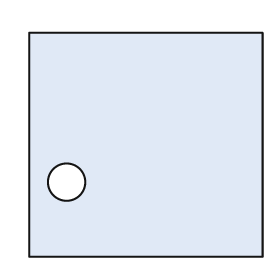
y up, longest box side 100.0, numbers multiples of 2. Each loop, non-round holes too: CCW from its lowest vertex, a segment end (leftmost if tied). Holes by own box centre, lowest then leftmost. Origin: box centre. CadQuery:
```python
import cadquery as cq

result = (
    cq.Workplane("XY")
    .moveTo(-50.0, -48.0)
    .lineTo(50.0, -48.0)
    .lineTo(50.0, 48.0)
    .lineTo(-50.0, 48.0)
    .close()
    .moveTo(-34.0, -16.0)
    .circle(8.0)
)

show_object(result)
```